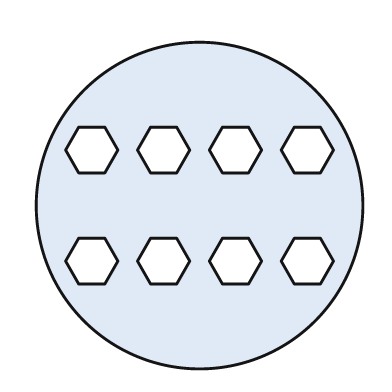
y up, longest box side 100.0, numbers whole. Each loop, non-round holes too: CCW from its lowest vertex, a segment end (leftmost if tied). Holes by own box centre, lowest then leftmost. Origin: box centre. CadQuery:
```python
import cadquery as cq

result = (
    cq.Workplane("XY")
    .moveTo(0.0, 0.0)
    .circle(50.0)
    .moveTo(-37.0, -24.0)
    .lineTo(-29.0, -24.0)
    .lineTo(-25.0, -17.0)
    .lineTo(-29.0, -10.0)
    .lineTo(-37.0, -10.0)
    .lineTo(-41.0, -17.0)
    .close()
    .moveTo(-15.0, -24.0)
    .lineTo(-7.0, -24.0)
    .lineTo(-3.0, -17.0)
    .lineTo(-7.0, -10.0)
    .lineTo(-15.0, -10.0)
    .lineTo(-19.0, -17.0)
    .close()
    .moveTo(7.0, -24.0)
    .lineTo(15.0, -24.0)
    .lineTo(19.0, -17.0)
    .lineTo(15.0, -10.0)
    .lineTo(7.0, -10.0)
    .lineTo(3.0, -17.0)
    .close()
    .moveTo(29.0, -24.0)
    .lineTo(37.0, -24.0)
    .lineTo(41.0, -17.0)
    .lineTo(37.0, -10.0)
    .lineTo(29.0, -10.0)
    .lineTo(25.0, -17.0)
    .close()
    .moveTo(-37.0, 10.0)
    .lineTo(-29.0, 10.0)
    .lineTo(-25.0, 17.0)
    .lineTo(-29.0, 24.0)
    .lineTo(-37.0, 24.0)
    .lineTo(-41.0, 17.0)
    .close()
    .moveTo(-15.0, 10.0)
    .lineTo(-7.0, 10.0)
    .lineTo(-3.0, 17.0)
    .lineTo(-7.0, 24.0)
    .lineTo(-15.0, 24.0)
    .lineTo(-19.0, 17.0)
    .close()
    .moveTo(7.0, 10.0)
    .lineTo(15.0, 10.0)
    .lineTo(19.0, 17.0)
    .lineTo(15.0, 24.0)
    .lineTo(7.0, 24.0)
    .lineTo(3.0, 17.0)
    .close()
    .moveTo(29.0, 10.0)
    .lineTo(37.0, 10.0)
    .lineTo(41.0, 17.0)
    .lineTo(37.0, 24.0)
    .lineTo(29.0, 24.0)
    .lineTo(25.0, 17.0)
    .close()
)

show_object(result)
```